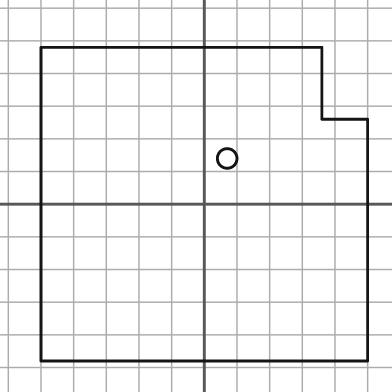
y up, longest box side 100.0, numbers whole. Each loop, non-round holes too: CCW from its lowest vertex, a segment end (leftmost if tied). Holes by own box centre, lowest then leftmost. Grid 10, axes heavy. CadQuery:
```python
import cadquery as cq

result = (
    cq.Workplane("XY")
    .moveTo(-50.0, -48.0)
    .lineTo(50.0, -48.0)
    .lineTo(50.0, 26.0)
    .lineTo(36.0, 26.0)
    .lineTo(36.0, 48.0)
    .lineTo(-50.0, 48.0)
    .close()
    .moveTo(7.0, 14.0)
    .circle(3.0)
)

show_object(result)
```